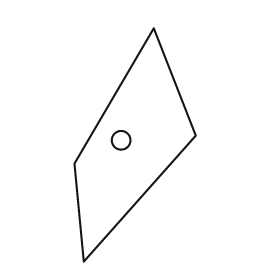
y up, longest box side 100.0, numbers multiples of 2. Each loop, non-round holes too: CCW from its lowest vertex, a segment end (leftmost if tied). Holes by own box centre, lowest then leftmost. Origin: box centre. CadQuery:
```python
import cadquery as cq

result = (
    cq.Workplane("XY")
    .moveTo(-22.0, -50.0)
    .lineTo(26.0, 4.0)
    .lineTo(8.0, 50.0)
    .lineTo(-26.0, -8.0)
    .close()
    .moveTo(-6.0, 2.0)
    .circle(4.0)
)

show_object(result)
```